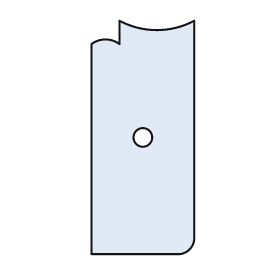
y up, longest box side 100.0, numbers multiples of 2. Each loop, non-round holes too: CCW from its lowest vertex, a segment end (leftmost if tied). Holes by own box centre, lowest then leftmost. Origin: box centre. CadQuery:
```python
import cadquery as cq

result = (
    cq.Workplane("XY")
    .moveTo(-22.0, -50.0)
    .lineTo(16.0, -50.0)
    .threePointArc((20.0, -48.0), (22.0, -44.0))
    .lineTo(22.0, 50.0)
    .threePointArc((6.0, 46.0), (-10.0, 50.0))
    .lineTo(-10.0, 40.0)
    .threePointArc((-16.0, 42.0), (-22.0, 40.0))
    .close()
    .moveTo(0.0, 0.0)
    .circle(4.0)
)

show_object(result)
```